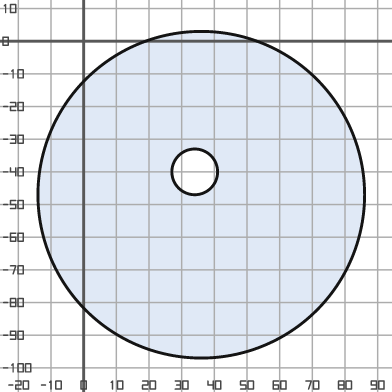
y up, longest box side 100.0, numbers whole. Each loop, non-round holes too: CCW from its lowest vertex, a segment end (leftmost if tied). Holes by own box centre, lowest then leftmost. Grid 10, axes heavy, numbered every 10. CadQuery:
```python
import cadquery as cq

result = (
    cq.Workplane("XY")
    .moveTo(36.0, -47.0)
    .circle(50.0)
    .moveTo(34.0, -40.0)
    .circle(7.0)
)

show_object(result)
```